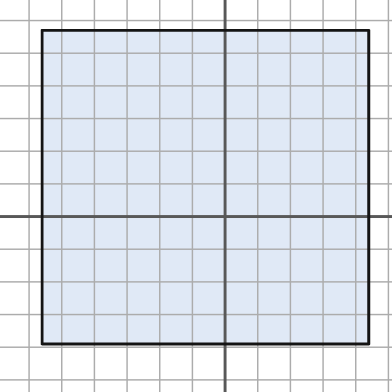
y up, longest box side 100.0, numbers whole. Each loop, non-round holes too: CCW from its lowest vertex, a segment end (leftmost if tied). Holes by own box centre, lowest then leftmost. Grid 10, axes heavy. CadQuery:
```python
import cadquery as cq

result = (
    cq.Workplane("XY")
    .moveTo(-56.0, -39.0)
    .lineTo(44.0, -39.0)
    .lineTo(44.0, 57.0)
    .lineTo(-56.0, 57.0)
    .close()
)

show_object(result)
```